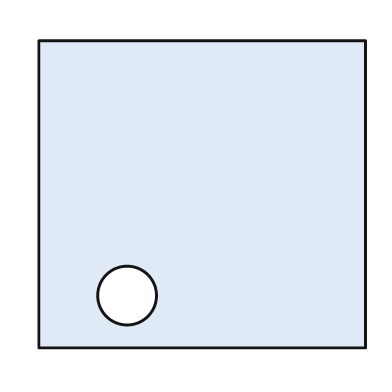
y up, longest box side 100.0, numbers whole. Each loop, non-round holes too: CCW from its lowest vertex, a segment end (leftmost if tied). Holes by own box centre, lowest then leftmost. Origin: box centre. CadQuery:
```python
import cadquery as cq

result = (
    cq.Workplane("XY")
    .moveTo(-50.0, -47.0)
    .lineTo(50.0, -47.0)
    .lineTo(50.0, 47.0)
    .lineTo(-50.0, 47.0)
    .close()
    .moveTo(-23.0, -31.0)
    .circle(9.0)
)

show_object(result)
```